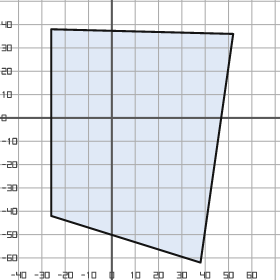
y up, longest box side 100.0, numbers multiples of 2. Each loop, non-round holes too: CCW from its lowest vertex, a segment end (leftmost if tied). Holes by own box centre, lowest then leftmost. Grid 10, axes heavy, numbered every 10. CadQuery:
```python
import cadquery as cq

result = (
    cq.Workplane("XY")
    .moveTo(38.0, -62.0)
    .lineTo(52.0, 36.0)
    .lineTo(-26.0, 38.0)
    .lineTo(-26.0, -42.0)
    .close()
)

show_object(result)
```